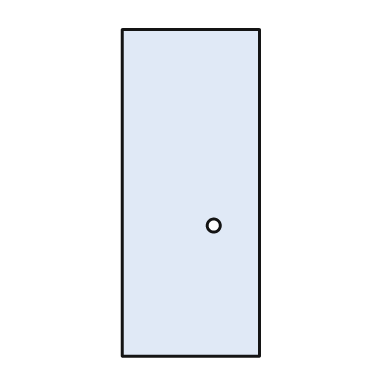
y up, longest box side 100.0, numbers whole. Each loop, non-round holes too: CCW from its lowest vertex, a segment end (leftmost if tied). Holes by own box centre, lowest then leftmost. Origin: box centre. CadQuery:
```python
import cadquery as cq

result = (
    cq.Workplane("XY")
    .moveTo(-21.0, -50.0)
    .lineTo(21.0, -50.0)
    .lineTo(21.0, 50.0)
    .lineTo(-21.0, 50.0)
    .close()
    .moveTo(7.0, -10.0)
    .circle(2.0)
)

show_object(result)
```